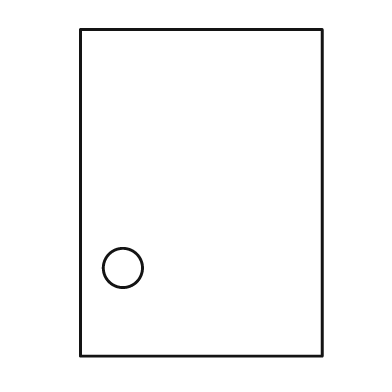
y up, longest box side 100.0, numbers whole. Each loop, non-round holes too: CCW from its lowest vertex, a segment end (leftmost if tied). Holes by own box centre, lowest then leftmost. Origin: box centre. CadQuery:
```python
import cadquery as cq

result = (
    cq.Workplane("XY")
    .moveTo(-37.0, -50.0)
    .lineTo(37.0, -50.0)
    .lineTo(37.0, 50.0)
    .lineTo(-37.0, 50.0)
    .close()
    .moveTo(-24.0, -23.0)
    .circle(6.0)
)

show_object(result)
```